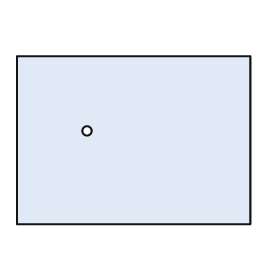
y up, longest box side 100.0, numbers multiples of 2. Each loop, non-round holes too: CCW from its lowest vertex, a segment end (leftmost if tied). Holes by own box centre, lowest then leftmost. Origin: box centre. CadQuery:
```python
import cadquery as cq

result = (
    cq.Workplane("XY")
    .moveTo(-50.0, -36.0)
    .lineTo(50.0, -36.0)
    .lineTo(50.0, 36.0)
    .lineTo(-50.0, 36.0)
    .close()
    .moveTo(-20.0, 4.0)
    .circle(2.0)
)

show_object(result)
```